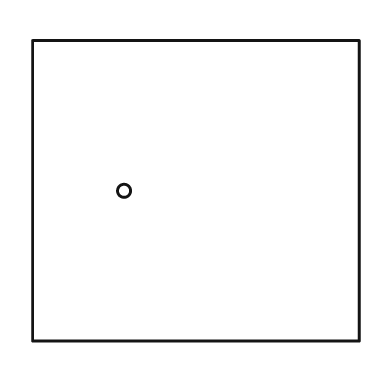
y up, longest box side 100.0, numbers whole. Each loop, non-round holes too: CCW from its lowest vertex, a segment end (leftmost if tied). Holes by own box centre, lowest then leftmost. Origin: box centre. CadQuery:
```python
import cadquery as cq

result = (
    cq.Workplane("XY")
    .moveTo(-50.0, -46.0)
    .lineTo(50.0, -46.0)
    .lineTo(50.0, 46.0)
    .lineTo(-50.0, 46.0)
    .close()
    .moveTo(-22.0, 0.0)
    .circle(2.0)
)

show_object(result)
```